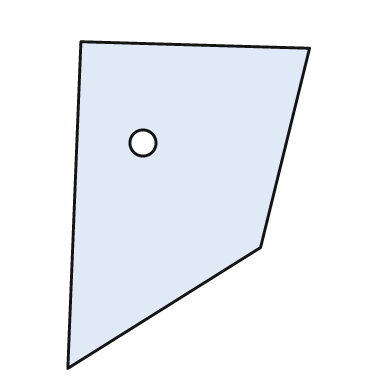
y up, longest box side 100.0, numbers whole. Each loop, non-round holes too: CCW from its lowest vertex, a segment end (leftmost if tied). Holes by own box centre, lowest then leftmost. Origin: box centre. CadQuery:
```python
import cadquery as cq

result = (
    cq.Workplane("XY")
    .moveTo(-37.0, -50.0)
    .lineTo(22.0, -13.0)
    .lineTo(37.0, 48.0)
    .lineTo(-33.0, 50.0)
    .close()
    .moveTo(-14.0, 19.0)
    .circle(4.0)
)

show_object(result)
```